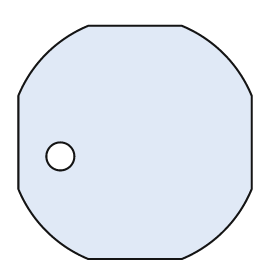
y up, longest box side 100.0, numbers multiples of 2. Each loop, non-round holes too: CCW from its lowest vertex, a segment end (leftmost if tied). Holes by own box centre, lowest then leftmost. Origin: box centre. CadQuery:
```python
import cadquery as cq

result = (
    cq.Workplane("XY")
    .moveTo(-20.0, -50.0)
    .lineTo(20.0, -50.0)
    .threePointArc((38.0, -38.0), (50.0, -20.0))
    .lineTo(50.0, 20.0)
    .threePointArc((38.0, 38.0), (20.0, 50.0))
    .lineTo(-20.0, 50.0)
    .threePointArc((-38.0, 38.0), (-50.0, 20.0))
    .lineTo(-50.0, -20.0)
    .threePointArc((-38.0, -38.0), (-20.0, -50.0))
    .close()
    .moveTo(-32.0, -6.0)
    .circle(6.0)
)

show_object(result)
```